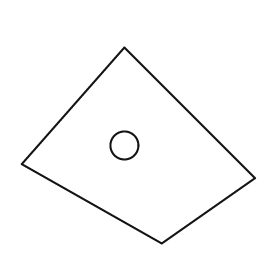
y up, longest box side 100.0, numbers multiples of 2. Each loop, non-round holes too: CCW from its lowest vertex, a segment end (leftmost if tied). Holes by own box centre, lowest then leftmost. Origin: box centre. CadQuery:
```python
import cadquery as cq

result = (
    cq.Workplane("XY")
    .moveTo(10.0, -42.0)
    .lineTo(50.0, -14.0)
    .lineTo(-6.0, 42.0)
    .lineTo(-50.0, -8.0)
    .close()
    .moveTo(-6.0, 0.0)
    .circle(6.0)
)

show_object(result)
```